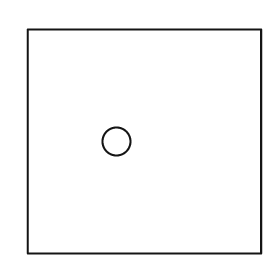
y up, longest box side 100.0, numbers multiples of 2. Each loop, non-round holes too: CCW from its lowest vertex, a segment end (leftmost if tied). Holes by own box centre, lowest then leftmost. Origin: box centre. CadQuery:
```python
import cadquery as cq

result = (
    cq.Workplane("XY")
    .moveTo(-50.0, -48.0)
    .lineTo(50.0, -48.0)
    .lineTo(50.0, 48.0)
    .lineTo(-50.0, 48.0)
    .close()
    .moveTo(-12.0, 0.0)
    .circle(6.0)
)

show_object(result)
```